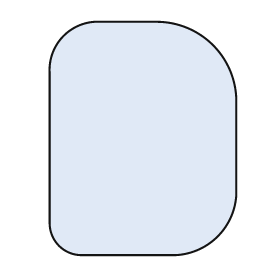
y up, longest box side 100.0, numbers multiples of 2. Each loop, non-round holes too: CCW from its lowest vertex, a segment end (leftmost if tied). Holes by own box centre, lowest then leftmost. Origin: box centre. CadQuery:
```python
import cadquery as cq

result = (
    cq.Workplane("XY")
    .moveTo(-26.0, -50.0)
    .lineTo(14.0, -50.0)
    .threePointArc((32.0, -42.0), (40.0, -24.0))
    .lineTo(40.0, 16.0)
    .threePointArc((30.0, 40.0), (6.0, 50.0))
    .lineTo(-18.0, 50.0)
    .threePointArc((-34.0, 44.0), (-40.0, 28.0))
    .lineTo(-40.0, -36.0)
    .threePointArc((-36.0, -46.0), (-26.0, -50.0))
    .close()
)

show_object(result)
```